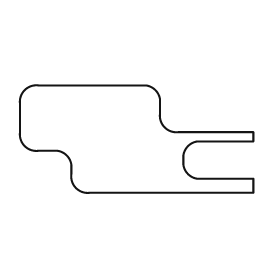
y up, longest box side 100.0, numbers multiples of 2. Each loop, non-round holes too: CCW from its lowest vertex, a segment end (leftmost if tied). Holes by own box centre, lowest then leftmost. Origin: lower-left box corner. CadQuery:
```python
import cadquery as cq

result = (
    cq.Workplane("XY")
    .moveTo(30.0, 0.0)
    .lineTo(100.0, 0.0)
    .lineTo(100.0, 6.0)
    .lineTo(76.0, 6.0)
    .threePointArc((72.0, 8.0), (70.0, 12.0))
    .lineTo(70.0, 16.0)
    .threePointArc((72.0, 20.0), (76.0, 22.0))
    .lineTo(100.0, 22.0)
    .lineTo(100.0, 26.0)
    .lineTo(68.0, 26.0)
    .threePointArc((62.0, 28.0), (60.0, 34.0))
    .lineTo(60.0, 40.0)
    .threePointArc((58.0, 44.0), (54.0, 46.0))
    .lineTo(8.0, 46.0)
    .threePointArc((2.0, 44.0), (0.0, 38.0))
    .lineTo(0.0, 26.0)
    .threePointArc((2.0, 20.0), (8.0, 18.0))
    .lineTo(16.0, 18.0)
    .threePointArc((20.0, 16.0), (22.0, 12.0))
    .lineTo(22.0, 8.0)
    .threePointArc((24.0, 2.0), (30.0, 0.0))
    .close()
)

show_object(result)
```